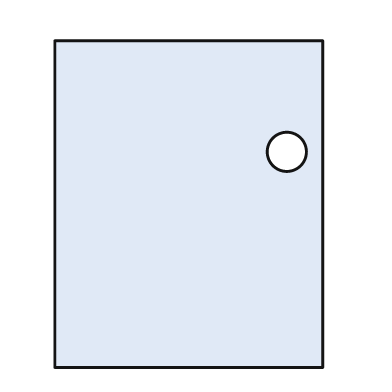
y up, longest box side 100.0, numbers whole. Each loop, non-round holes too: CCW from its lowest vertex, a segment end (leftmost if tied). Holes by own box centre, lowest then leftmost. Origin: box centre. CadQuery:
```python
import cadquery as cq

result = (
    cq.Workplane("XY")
    .moveTo(-41.0, -50.0)
    .lineTo(41.0, -50.0)
    .lineTo(41.0, 50.0)
    .lineTo(-41.0, 50.0)
    .close()
    .moveTo(30.0, 16.0)
    .circle(6.0)
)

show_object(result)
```